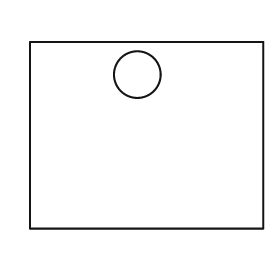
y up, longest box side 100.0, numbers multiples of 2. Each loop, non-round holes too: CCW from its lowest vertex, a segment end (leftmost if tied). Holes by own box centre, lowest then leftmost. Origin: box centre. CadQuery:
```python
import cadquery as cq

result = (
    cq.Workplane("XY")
    .moveTo(-50.0, -40.0)
    .lineTo(50.0, -40.0)
    .lineTo(50.0, 40.0)
    .lineTo(-50.0, 40.0)
    .close()
    .moveTo(-4.0, 26.0)
    .circle(10.0)
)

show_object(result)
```